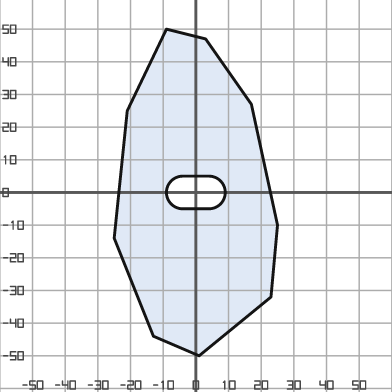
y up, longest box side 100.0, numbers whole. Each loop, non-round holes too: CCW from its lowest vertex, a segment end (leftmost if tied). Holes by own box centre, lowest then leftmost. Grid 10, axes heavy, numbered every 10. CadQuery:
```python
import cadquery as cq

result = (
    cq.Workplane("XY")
    .moveTo(1.0, -50.0)
    .lineTo(23.0, -32.0)
    .lineTo(25.0, -10.0)
    .lineTo(17.0, 27.0)
    .lineTo(3.0, 47.0)
    .lineTo(-9.0, 50.0)
    .lineTo(-21.0, 25.0)
    .lineTo(-25.0, -14.0)
    .lineTo(-13.0, -44.0)
    .close()
    .moveTo(-4.0, -5.0)
    .lineTo(4.0, -5.0)
    .threePointArc((9.0, 0.0), (4.0, 5.0))
    .lineTo(-4.0, 5.0)
    .threePointArc((-9.0, 0.0), (-4.0, -5.0))
    .close()
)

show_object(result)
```